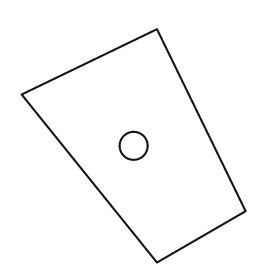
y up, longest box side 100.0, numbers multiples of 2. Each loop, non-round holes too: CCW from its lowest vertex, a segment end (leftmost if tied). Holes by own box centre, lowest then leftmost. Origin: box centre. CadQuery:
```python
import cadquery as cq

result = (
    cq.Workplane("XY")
    .moveTo(10.0, -50.0)
    .lineTo(48.0, -28.0)
    .lineTo(10.0, 50.0)
    .lineTo(-48.0, 22.0)
    .close()
    .moveTo(0.0, 0.0)
    .circle(6.0)
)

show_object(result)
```